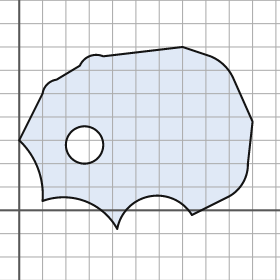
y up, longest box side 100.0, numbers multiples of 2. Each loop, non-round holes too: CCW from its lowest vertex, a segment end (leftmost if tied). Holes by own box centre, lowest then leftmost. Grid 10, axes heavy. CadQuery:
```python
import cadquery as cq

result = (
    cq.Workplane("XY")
    .moveTo(42.0, -8.0)
    .threePointArc((56.0, 6.0), (74.0, -2.0))
    .lineTo(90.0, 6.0)
    .threePointArc((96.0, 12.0), (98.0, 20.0))
    .lineTo(100.0, 38.0)
    .lineTo(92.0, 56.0)
    .threePointArc((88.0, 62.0), (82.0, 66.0))
    .lineTo(70.0, 70.0)
    .lineTo(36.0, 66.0)
    .threePointArc((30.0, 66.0), (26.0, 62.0))
    .lineTo(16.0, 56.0)
    .threePointArc((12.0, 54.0), (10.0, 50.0))
    .lineTo(0.0, 30.0)
    .threePointArc((8.0, 18.0), (10.0, 4.0))
    .threePointArc((28.0, 4.0), (42.0, -8.0))
    .close()
    .moveTo(28.0, 28.0)
    .circle(8.0)
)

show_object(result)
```